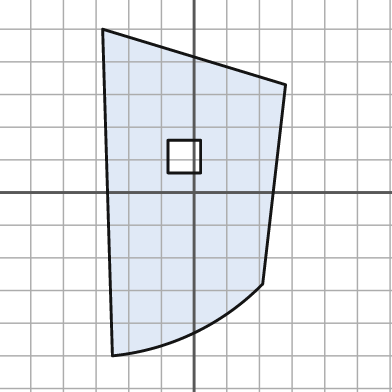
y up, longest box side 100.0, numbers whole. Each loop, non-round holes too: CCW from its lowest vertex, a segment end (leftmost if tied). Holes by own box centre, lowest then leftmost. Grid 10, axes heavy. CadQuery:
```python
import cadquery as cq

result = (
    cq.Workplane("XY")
    .moveTo(-25.0, -50.0)
    .threePointArc((0.0, -43.0), (21.0, -28.0))
    .lineTo(28.0, 33.0)
    .lineTo(-28.0, 50.0)
    .close()
    .moveTo(-8.0, 6.0)
    .lineTo(2.0, 6.0)
    .lineTo(2.0, 16.0)
    .lineTo(-8.0, 16.0)
    .close()
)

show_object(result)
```